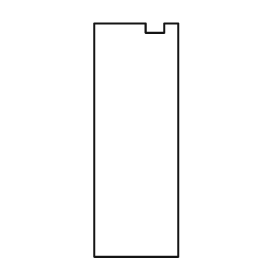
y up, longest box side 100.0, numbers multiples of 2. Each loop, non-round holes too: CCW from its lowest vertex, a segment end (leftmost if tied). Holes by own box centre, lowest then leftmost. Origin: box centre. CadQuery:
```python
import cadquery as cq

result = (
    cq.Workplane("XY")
    .moveTo(-18.0, -50.0)
    .lineTo(18.0, -50.0)
    .lineTo(18.0, 50.0)
    .lineTo(12.0, 50.0)
    .lineTo(12.0, 46.0)
    .lineTo(4.0, 46.0)
    .lineTo(4.0, 50.0)
    .lineTo(-18.0, 50.0)
    .close()
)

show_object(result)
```